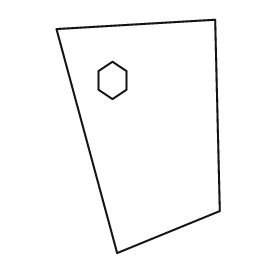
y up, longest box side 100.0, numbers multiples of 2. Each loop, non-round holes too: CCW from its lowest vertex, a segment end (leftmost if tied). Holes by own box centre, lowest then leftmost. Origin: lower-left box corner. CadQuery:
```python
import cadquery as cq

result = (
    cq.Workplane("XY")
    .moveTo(26.0, 0.0)
    .lineTo(70.0, 18.0)
    .lineTo(68.0, 100.0)
    .lineTo(0.0, 96.0)
    .close()
    .moveTo(24.0, 66.0)
    .lineTo(30.0, 70.0)
    .lineTo(30.0, 78.0)
    .lineTo(24.0, 82.0)
    .lineTo(18.0, 78.0)
    .lineTo(18.0, 70.0)
    .close()
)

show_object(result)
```